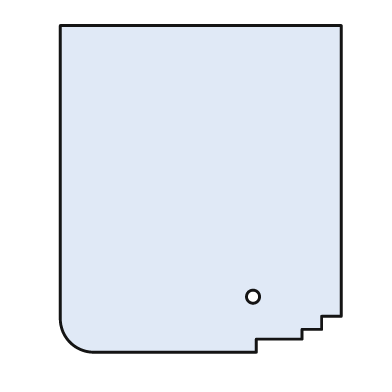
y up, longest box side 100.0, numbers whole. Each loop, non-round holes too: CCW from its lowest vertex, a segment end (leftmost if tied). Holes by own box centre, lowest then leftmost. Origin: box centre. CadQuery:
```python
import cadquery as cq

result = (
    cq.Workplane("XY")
    .moveTo(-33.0, -50.0)
    .lineTo(17.0, -50.0)
    .lineTo(17.0, -46.0)
    .lineTo(31.0, -46.0)
    .lineTo(31.0, -43.0)
    .lineTo(37.0, -43.0)
    .lineTo(37.0, -39.0)
    .lineTo(43.0, -39.0)
    .lineTo(43.0, 50.0)
    .lineTo(-43.0, 50.0)
    .lineTo(-43.0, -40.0)
    .threePointArc((-40.0, -47.0), (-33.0, -50.0))
    .close()
    .moveTo(16.0, -33.0)
    .circle(2.0)
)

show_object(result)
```